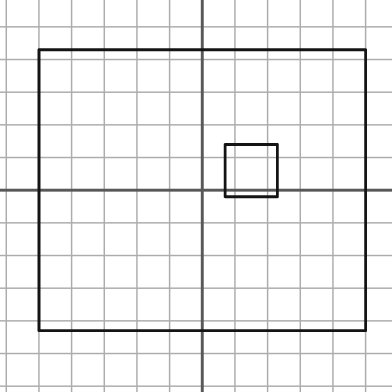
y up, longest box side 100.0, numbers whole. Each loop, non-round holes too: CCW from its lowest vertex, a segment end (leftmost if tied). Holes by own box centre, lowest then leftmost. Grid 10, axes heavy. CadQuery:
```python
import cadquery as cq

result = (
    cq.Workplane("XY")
    .moveTo(-50.0, -43.0)
    .lineTo(50.0, -43.0)
    .lineTo(50.0, 43.0)
    .lineTo(-50.0, 43.0)
    .close()
    .moveTo(7.0, -2.0)
    .lineTo(23.0, -2.0)
    .lineTo(23.0, 14.0)
    .lineTo(7.0, 14.0)
    .close()
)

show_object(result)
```